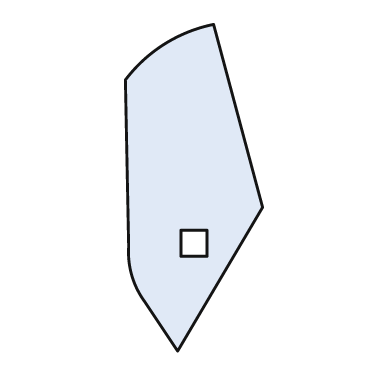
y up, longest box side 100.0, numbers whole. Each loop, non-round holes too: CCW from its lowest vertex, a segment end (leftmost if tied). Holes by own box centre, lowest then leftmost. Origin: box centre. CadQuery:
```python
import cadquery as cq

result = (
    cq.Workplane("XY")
    .moveTo(-5.0, -50.0)
    .lineTo(21.0, -6.0)
    .lineTo(6.0, 50.0)
    .threePointArc((-9.0, 44.0), (-21.0, 33.0))
    .lineTo(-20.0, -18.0)
    .threePointArc((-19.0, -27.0), (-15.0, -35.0))
    .close()
    .moveTo(-4.0, -21.0)
    .lineTo(4.0, -21.0)
    .lineTo(4.0, -13.0)
    .lineTo(-4.0, -13.0)
    .close()
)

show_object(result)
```